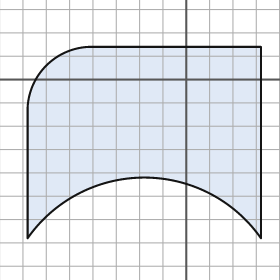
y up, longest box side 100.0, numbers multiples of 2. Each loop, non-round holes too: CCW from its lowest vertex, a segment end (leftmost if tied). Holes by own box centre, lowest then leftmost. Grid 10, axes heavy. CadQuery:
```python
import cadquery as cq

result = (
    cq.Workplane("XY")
    .moveTo(-68.0, -68.0)
    .threePointArc((-18.0, -42.0), (32.0, -68.0))
    .lineTo(32.0, 14.0)
    .lineTo(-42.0, 14.0)
    .threePointArc((-60.0, 6.0), (-68.0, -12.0))
    .close()
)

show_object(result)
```